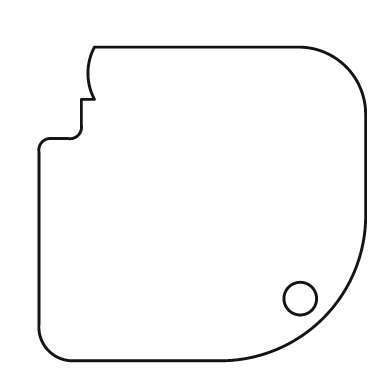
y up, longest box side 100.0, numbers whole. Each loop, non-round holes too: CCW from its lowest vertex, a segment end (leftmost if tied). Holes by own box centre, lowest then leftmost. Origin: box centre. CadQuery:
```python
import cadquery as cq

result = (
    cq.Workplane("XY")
    .moveTo(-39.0, -48.0)
    .lineTo(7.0, -48.0)
    .threePointArc((37.0, -35.0), (50.0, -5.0))
    .lineTo(50.0, 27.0)
    .threePointArc((44.0, 42.0), (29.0, 48.0))
    .lineTo(-33.0, 48.0)
    .threePointArc((-35.0, 40.0), (-33.0, 32.0))
    .lineTo(-37.0, 32.0)
    .lineTo(-37.0, 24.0)
    .threePointArc((-38.0, 21.0), (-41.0, 20.0))
    .lineTo(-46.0, 20.0)
    .threePointArc((-49.0, 19.0), (-50.0, 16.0))
    .lineTo(-50.0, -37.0)
    .threePointArc((-47.0, -45.0), (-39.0, -48.0))
    .close()
    .moveTo(30.0, -29.0)
    .circle(5.0)
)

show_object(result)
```